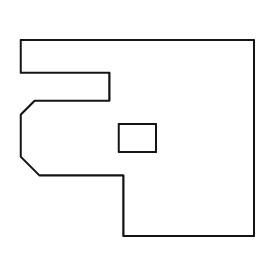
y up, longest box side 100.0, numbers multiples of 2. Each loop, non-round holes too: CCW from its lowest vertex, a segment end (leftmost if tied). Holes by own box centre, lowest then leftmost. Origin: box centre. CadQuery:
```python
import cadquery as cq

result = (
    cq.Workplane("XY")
    .moveTo(-6.0, -42.0)
    .lineTo(50.0, -42.0)
    .lineTo(50.0, 42.0)
    .lineTo(-50.0, 42.0)
    .lineTo(-50.0, 28.0)
    .lineTo(-12.0, 28.0)
    .lineTo(-12.0, 16.0)
    .lineTo(-44.0, 16.0)
    .lineTo(-50.0, 10.0)
    .lineTo(-50.0, -8.0)
    .lineTo(-42.0, -16.0)
    .lineTo(-6.0, -16.0)
    .close()
    .moveTo(-8.0, -6.0)
    .lineTo(8.0, -6.0)
    .lineTo(8.0, 6.0)
    .lineTo(-8.0, 6.0)
    .close()
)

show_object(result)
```